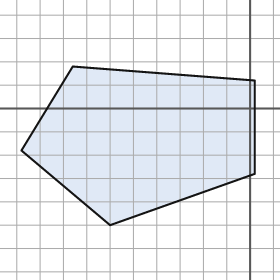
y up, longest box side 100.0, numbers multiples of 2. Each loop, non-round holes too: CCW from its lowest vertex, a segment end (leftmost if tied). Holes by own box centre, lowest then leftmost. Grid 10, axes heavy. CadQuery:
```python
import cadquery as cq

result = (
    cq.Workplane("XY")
    .moveTo(-60.0, -50.0)
    .lineTo(2.0, -28.0)
    .lineTo(2.0, 12.0)
    .lineTo(-76.0, 18.0)
    .lineTo(-98.0, -18.0)
    .close()
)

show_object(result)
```